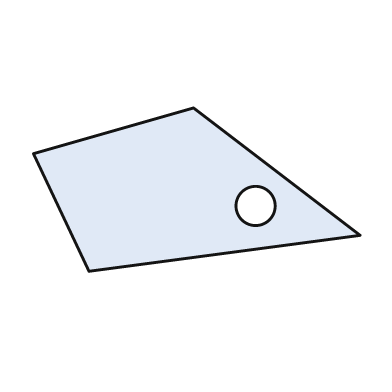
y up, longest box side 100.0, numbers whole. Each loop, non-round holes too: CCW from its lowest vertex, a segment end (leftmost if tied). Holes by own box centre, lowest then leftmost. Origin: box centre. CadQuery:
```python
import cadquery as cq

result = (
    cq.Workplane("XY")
    .moveTo(-33.0, -25.0)
    .lineTo(50.0, -14.0)
    .lineTo(-1.0, 25.0)
    .lineTo(-50.0, 11.0)
    .close()
    .moveTo(18.0, -5.0)
    .circle(6.0)
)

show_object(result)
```